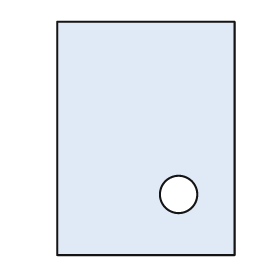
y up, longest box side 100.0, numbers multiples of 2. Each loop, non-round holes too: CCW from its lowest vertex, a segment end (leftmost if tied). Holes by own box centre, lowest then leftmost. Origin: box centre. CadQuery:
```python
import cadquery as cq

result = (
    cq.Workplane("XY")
    .moveTo(-38.0, -50.0)
    .lineTo(38.0, -50.0)
    .lineTo(38.0, 50.0)
    .lineTo(-38.0, 50.0)
    .close()
    .moveTo(14.0, -24.0)
    .circle(8.0)
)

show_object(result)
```